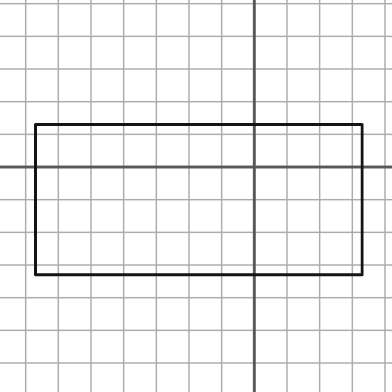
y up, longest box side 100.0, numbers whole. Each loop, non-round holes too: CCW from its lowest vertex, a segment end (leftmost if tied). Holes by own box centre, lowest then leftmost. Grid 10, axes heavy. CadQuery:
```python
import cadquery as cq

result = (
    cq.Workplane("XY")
    .moveTo(-67.0, -33.0)
    .lineTo(33.0, -33.0)
    .lineTo(33.0, 13.0)
    .lineTo(-67.0, 13.0)
    .close()
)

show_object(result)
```